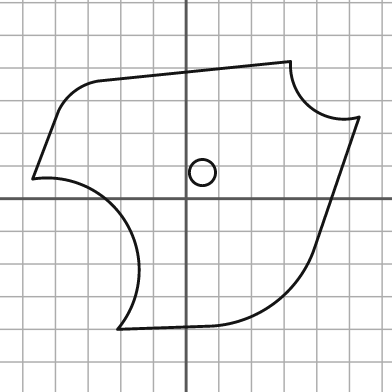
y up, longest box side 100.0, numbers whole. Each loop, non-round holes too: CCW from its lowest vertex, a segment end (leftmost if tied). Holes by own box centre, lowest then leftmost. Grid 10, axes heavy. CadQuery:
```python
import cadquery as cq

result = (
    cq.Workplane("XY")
    .moveTo(-21.0, -40.0)
    .lineTo(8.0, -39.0)
    .threePointArc((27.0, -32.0), (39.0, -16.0))
    .lineTo(53.0, 25.0)
    .threePointArc((38.0, 28.0), (32.0, 42.0))
    .lineTo(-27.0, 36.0)
    .threePointArc((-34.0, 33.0), (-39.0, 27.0))
    .lineTo(-47.0, 6.0)
    .threePointArc((-18.0, -8.0), (-21.0, -40.0))
    .close()
    .moveTo(5.0, 8.0)
    .circle(4.0)
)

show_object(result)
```